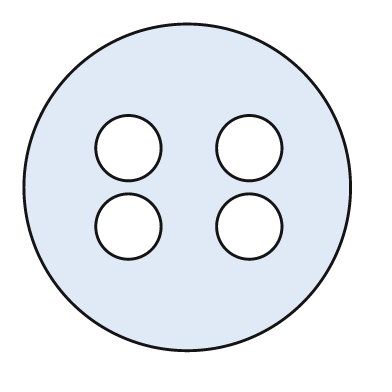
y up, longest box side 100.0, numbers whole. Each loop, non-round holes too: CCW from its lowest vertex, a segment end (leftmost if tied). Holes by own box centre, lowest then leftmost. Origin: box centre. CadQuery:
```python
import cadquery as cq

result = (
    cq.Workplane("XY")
    .moveTo(0.0, 0.0)
    .circle(50.0)
    .moveTo(-18.0, -12.0)
    .circle(10.0)
    .moveTo(19.0, -12.0)
    .circle(10.0)
    .moveTo(-18.0, 12.0)
    .circle(10.0)
    .moveTo(19.0, 12.0)
    .circle(10.0)
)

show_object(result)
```